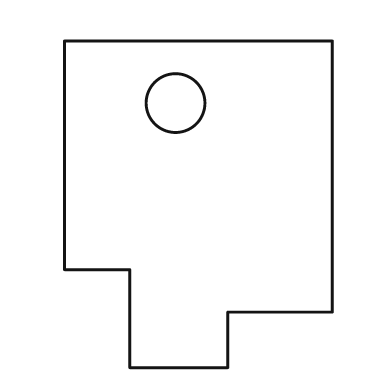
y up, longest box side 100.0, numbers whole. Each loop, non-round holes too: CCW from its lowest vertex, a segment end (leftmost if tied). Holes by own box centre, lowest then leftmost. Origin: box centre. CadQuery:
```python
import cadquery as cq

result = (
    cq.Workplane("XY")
    .moveTo(-21.0, -50.0)
    .lineTo(9.0, -50.0)
    .lineTo(9.0, -33.0)
    .lineTo(41.0, -33.0)
    .lineTo(41.0, 50.0)
    .lineTo(-41.0, 50.0)
    .lineTo(-41.0, -20.0)
    .lineTo(-21.0, -20.0)
    .close()
    .moveTo(-7.0, 31.0)
    .circle(9.0)
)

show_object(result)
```